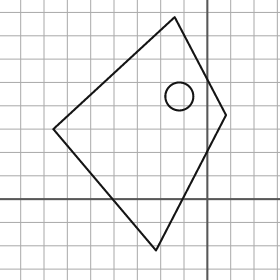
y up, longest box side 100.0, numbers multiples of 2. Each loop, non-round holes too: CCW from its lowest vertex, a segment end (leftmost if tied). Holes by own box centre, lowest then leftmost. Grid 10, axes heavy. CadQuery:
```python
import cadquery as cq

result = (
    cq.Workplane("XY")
    .moveTo(-22.0, -22.0)
    .lineTo(8.0, 36.0)
    .lineTo(-14.0, 78.0)
    .lineTo(-66.0, 30.0)
    .close()
    .moveTo(-12.0, 44.0)
    .circle(6.0)
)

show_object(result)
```